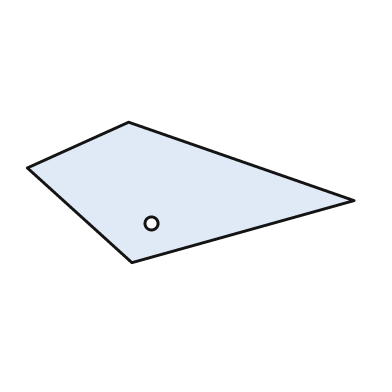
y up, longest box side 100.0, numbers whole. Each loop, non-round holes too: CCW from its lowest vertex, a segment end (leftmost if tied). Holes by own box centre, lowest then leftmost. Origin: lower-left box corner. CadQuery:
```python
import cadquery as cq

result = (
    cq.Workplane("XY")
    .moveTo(32.0, 0.0)
    .lineTo(100.0, 19.0)
    .lineTo(31.0, 43.0)
    .lineTo(0.0, 29.0)
    .close()
    .moveTo(38.0, 12.0)
    .circle(2.0)
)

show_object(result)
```